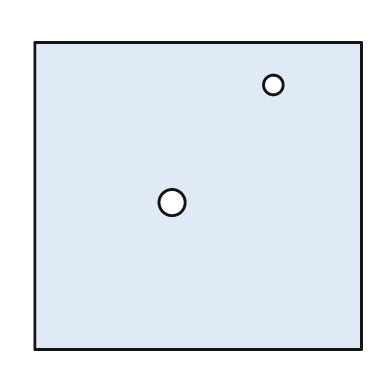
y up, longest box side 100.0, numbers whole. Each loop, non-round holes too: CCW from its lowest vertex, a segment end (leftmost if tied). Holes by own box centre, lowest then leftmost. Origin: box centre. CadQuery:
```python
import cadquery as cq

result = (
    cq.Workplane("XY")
    .moveTo(-50.0, -47.0)
    .lineTo(50.0, -47.0)
    .lineTo(50.0, 47.0)
    .lineTo(-50.0, 47.0)
    .close()
    .moveTo(-8.0, -2.0)
    .circle(4.0)
    .moveTo(23.0, 34.0)
    .circle(3.0)
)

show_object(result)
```